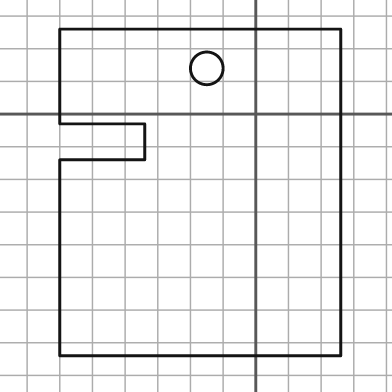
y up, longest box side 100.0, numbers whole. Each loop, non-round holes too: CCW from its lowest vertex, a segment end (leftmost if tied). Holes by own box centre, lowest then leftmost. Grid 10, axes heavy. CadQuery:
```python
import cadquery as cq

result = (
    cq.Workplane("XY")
    .moveTo(-60.0, -74.0)
    .lineTo(26.0, -74.0)
    .lineTo(26.0, 26.0)
    .lineTo(-60.0, 26.0)
    .lineTo(-60.0, -3.0)
    .lineTo(-34.0, -3.0)
    .lineTo(-34.0, -14.0)
    .lineTo(-60.0, -14.0)
    .close()
    .moveTo(-15.0, 14.0)
    .circle(5.0)
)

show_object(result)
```